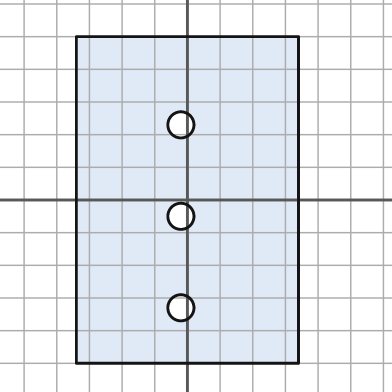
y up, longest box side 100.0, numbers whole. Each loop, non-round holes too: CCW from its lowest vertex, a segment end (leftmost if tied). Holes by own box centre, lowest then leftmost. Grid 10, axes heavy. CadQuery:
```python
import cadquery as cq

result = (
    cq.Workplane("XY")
    .moveTo(-34.0, -50.0)
    .lineTo(34.0, -50.0)
    .lineTo(34.0, 50.0)
    .lineTo(-34.0, 50.0)
    .close()
    .moveTo(-2.0, -33.0)
    .circle(4.0)
    .moveTo(-2.0, -5.0)
    .circle(4.0)
    .moveTo(-2.0, 23.0)
    .circle(4.0)
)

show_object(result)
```